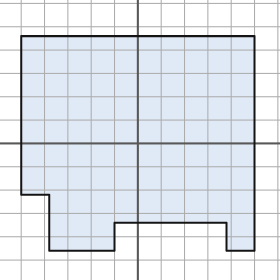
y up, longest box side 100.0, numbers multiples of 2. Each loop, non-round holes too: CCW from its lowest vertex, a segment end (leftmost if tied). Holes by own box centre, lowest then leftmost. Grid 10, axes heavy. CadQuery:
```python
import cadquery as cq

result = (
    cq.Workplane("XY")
    .moveTo(-38.0, -46.0)
    .lineTo(-10.0, -46.0)
    .lineTo(-10.0, -34.0)
    .lineTo(38.0, -34.0)
    .lineTo(38.0, -46.0)
    .lineTo(50.0, -46.0)
    .lineTo(50.0, 46.0)
    .lineTo(-50.0, 46.0)
    .lineTo(-50.0, -22.0)
    .lineTo(-38.0, -22.0)
    .close()
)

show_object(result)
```